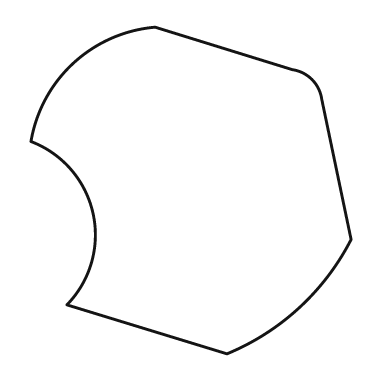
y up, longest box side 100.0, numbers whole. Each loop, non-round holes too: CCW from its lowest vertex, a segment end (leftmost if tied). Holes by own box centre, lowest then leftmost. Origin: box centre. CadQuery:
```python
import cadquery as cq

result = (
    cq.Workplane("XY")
    .moveTo(11.0, -50.0)
    .threePointArc((33.0, -36.0), (49.0, -15.0))
    .lineTo(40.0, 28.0)
    .threePointArc((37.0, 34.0), (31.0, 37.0))
    .lineTo(-11.0, 50.0)
    .threePointArc((-36.0, 39.0), (-49.0, 15.0))
    .threePointArc((-30.0, -7.0), (-38.0, -35.0))
    .close()
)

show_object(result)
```